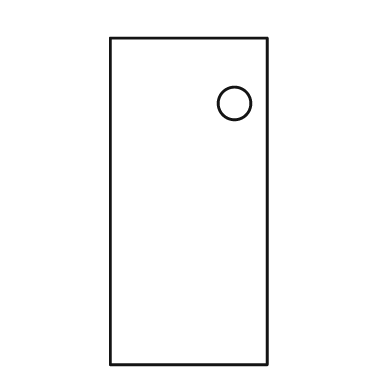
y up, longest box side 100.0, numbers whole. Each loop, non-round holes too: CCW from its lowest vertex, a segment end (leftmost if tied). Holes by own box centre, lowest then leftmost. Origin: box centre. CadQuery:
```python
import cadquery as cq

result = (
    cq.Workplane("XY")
    .moveTo(-24.0, -50.0)
    .lineTo(24.0, -50.0)
    .lineTo(24.0, 50.0)
    .lineTo(-24.0, 50.0)
    .close()
    .moveTo(14.0, 30.0)
    .circle(5.0)
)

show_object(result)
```